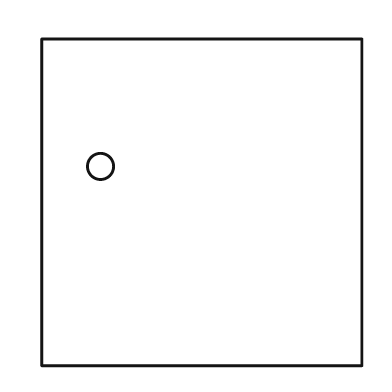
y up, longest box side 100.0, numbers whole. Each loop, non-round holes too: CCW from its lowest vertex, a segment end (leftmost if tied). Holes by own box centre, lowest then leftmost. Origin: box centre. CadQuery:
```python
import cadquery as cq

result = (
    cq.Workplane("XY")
    .moveTo(-49.0, -50.0)
    .lineTo(49.0, -50.0)
    .lineTo(49.0, 50.0)
    .lineTo(-49.0, 50.0)
    .close()
    .moveTo(-31.0, 11.0)
    .circle(4.0)
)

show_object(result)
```